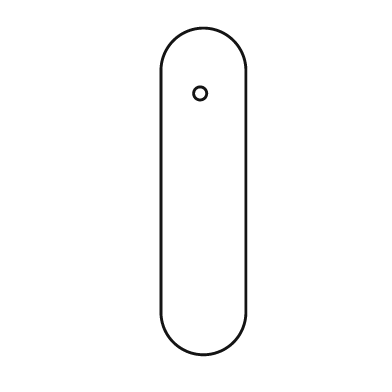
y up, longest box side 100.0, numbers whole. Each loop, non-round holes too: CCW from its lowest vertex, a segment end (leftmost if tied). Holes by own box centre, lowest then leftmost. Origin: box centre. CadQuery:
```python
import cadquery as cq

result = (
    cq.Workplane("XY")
    .moveTo(-13.0, -37.0)
    .threePointArc((0.0, -50.0), (13.0, -37.0))
    .lineTo(13.0, 37.0)
    .threePointArc((0.0, 50.0), (-13.0, 37.0))
    .close()
    .moveTo(-1.0, 30.0)
    .circle(2.0)
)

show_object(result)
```